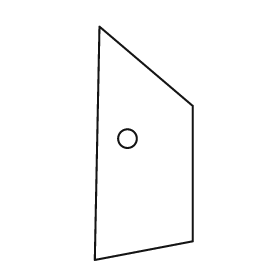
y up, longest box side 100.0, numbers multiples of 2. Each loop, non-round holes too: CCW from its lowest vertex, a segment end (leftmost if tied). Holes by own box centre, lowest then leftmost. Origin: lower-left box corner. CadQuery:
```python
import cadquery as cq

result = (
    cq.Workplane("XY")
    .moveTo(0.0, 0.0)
    .lineTo(42.0, 8.0)
    .lineTo(42.0, 66.0)
    .lineTo(2.0, 100.0)
    .close()
    .moveTo(14.0, 52.0)
    .circle(4.0)
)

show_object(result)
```